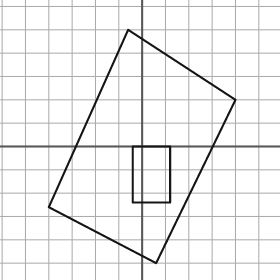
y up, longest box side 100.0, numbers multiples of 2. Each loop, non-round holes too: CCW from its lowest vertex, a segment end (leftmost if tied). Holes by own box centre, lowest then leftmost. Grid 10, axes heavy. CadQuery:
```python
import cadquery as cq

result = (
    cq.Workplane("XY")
    .moveTo(6.0, -50.0)
    .lineTo(40.0, 20.0)
    .lineTo(-6.0, 50.0)
    .lineTo(-40.0, -26.0)
    .close()
    .moveTo(-4.0, -24.0)
    .lineTo(12.0, -24.0)
    .lineTo(12.0, 0.0)
    .lineTo(-4.0, 0.0)
    .close()
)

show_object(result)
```